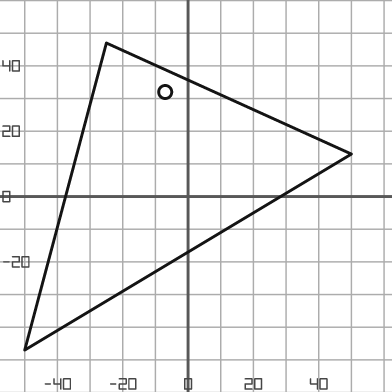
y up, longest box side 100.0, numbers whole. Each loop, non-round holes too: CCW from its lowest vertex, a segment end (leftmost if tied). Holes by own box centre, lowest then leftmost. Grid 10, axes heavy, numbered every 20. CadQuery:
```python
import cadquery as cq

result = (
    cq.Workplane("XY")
    .moveTo(-50.0, -47.0)
    .lineTo(50.0, 13.0)
    .lineTo(-25.0, 47.0)
    .close()
    .moveTo(-7.0, 32.0)
    .circle(2.0)
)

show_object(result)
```